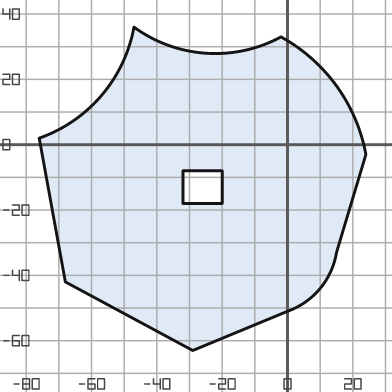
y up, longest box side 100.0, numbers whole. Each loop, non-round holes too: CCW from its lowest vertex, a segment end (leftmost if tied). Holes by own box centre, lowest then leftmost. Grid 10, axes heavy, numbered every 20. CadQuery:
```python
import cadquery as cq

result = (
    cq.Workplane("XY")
    .moveTo(-29.0, -63.0)
    .lineTo(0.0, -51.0)
    .threePointArc((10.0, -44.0), (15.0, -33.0))
    .lineTo(24.0, -3.0)
    .threePointArc((15.0, 18.0), (-2.0, 33.0))
    .threePointArc((-25.0, 28.0), (-47.0, 36.0))
    .threePointArc((-57.0, 15.0), (-76.0, 2.0))
    .lineTo(-68.0, -42.0)
    .close()
    .moveTo(-32.0, -18.0)
    .lineTo(-20.0, -18.0)
    .lineTo(-20.0, -8.0)
    .lineTo(-32.0, -8.0)
    .close()
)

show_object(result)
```